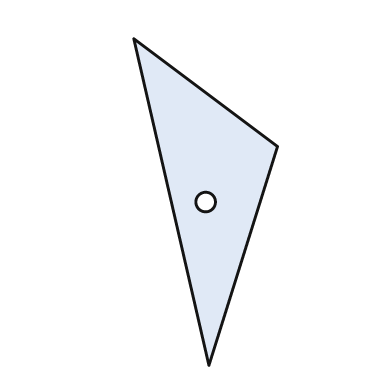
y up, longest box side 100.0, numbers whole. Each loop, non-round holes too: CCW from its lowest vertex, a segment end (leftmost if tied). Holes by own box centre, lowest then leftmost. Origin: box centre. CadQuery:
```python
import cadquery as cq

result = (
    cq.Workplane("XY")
    .moveTo(1.0, -50.0)
    .lineTo(22.0, 17.0)
    .lineTo(-22.0, 50.0)
    .close()
    .moveTo(0.0, 0.0)
    .circle(3.0)
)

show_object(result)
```